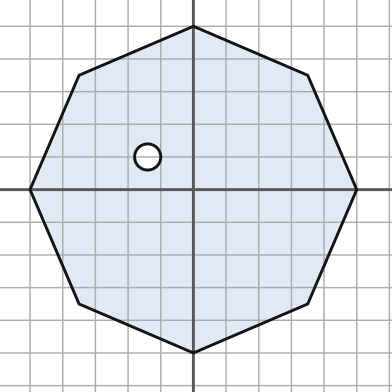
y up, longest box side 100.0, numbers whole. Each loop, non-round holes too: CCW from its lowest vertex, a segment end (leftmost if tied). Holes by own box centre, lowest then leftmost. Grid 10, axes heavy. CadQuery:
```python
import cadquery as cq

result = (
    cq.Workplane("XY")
    .moveTo(0.0, -50.0)
    .lineTo(35.0, -35.0)
    .lineTo(50.0, 0.0)
    .lineTo(35.0, 35.0)
    .lineTo(0.0, 50.0)
    .lineTo(-35.0, 35.0)
    .lineTo(-50.0, 0.0)
    .lineTo(-35.0, -35.0)
    .close()
    .moveTo(-14.0, 10.0)
    .circle(4.0)
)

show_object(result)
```